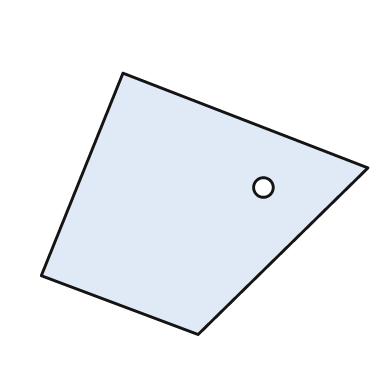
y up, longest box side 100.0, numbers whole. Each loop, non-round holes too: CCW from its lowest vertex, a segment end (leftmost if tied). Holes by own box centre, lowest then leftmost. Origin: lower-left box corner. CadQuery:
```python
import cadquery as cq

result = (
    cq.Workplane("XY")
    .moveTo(48.0, 0.0)
    .lineTo(100.0, 51.0)
    .lineTo(25.0, 80.0)
    .lineTo(0.0, 18.0)
    .close()
    .moveTo(68.0, 45.0)
    .circle(3.0)
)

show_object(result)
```